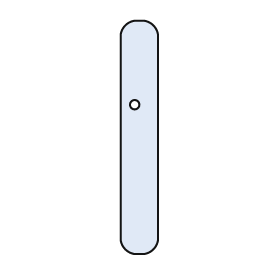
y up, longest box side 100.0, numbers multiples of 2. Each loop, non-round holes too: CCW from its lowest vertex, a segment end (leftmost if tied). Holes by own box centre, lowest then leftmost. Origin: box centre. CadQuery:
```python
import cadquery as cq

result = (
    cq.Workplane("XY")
    .moveTo(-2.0, -50.0)
    .lineTo(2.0, -50.0)
    .threePointArc((6.0, -48.0), (8.0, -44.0))
    .lineTo(8.0, 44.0)
    .threePointArc((6.0, 48.0), (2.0, 50.0))
    .lineTo(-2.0, 50.0)
    .threePointArc((-6.0, 48.0), (-8.0, 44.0))
    .lineTo(-8.0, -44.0)
    .threePointArc((-6.0, -48.0), (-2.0, -50.0))
    .close()
    .moveTo(-2.0, 14.0)
    .circle(2.0)
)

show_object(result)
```